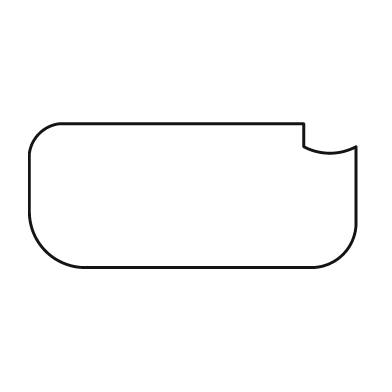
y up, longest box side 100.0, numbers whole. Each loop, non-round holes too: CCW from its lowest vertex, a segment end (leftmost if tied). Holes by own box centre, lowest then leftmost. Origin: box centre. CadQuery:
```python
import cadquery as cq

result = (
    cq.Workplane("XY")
    .moveTo(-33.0, -22.0)
    .lineTo(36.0, -22.0)
    .threePointArc((46.0, -18.0), (50.0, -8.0))
    .lineTo(50.0, 15.0)
    .threePointArc((42.0, 13.0), (34.0, 15.0))
    .lineTo(34.0, 22.0)
    .lineTo(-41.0, 22.0)
    .threePointArc((-47.0, 19.0), (-50.0, 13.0))
    .lineTo(-50.0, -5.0)
    .threePointArc((-45.0, -17.0), (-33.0, -22.0))
    .close()
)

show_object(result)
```